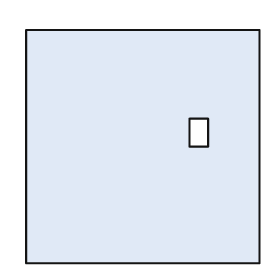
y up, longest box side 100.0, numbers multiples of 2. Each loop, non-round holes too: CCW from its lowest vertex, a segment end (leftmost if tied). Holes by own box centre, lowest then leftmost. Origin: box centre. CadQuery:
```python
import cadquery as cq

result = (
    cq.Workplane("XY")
    .moveTo(-50.0, -50.0)
    .lineTo(50.0, -50.0)
    .lineTo(50.0, 50.0)
    .lineTo(-50.0, 50.0)
    .close()
    .moveTo(20.0, 0.0)
    .lineTo(28.0, 0.0)
    .lineTo(28.0, 12.0)
    .lineTo(20.0, 12.0)
    .close()
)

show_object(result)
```